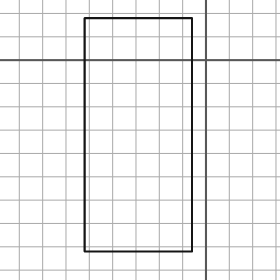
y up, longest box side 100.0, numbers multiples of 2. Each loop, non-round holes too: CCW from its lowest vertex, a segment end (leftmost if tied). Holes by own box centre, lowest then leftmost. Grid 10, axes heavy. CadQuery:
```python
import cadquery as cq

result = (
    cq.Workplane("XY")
    .moveTo(-52.0, -82.0)
    .lineTo(-6.0, -82.0)
    .lineTo(-6.0, 18.0)
    .lineTo(-52.0, 18.0)
    .close()
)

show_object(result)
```